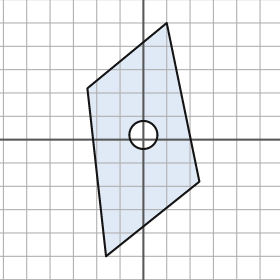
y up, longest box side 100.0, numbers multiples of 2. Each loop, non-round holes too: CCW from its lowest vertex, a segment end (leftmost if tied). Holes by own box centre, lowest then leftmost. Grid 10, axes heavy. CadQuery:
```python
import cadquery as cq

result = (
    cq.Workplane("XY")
    .moveTo(-16.0, -50.0)
    .lineTo(24.0, -18.0)
    .lineTo(10.0, 50.0)
    .lineTo(-24.0, 22.0)
    .close()
    .moveTo(0.0, 2.0)
    .circle(6.0)
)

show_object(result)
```